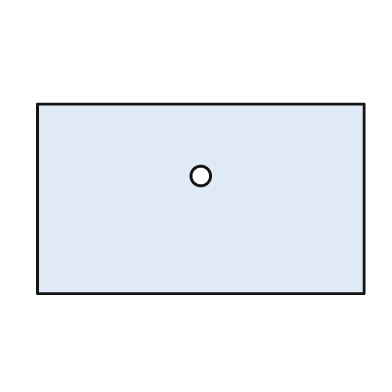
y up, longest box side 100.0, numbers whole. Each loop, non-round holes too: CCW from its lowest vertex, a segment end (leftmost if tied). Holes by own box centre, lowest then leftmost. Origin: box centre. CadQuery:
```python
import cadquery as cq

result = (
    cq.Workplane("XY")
    .moveTo(-50.0, -29.0)
    .lineTo(50.0, -29.0)
    .lineTo(50.0, 29.0)
    .lineTo(-50.0, 29.0)
    .close()
    .moveTo(0.0, 7.0)
    .circle(3.0)
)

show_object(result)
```